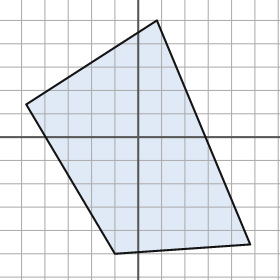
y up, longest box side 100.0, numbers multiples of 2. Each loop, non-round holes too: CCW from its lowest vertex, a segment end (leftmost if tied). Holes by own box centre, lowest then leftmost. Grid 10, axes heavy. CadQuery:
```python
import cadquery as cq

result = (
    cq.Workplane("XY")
    .moveTo(-10.0, -50.0)
    .lineTo(48.0, -46.0)
    .lineTo(8.0, 50.0)
    .lineTo(-48.0, 14.0)
    .close()
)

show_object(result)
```